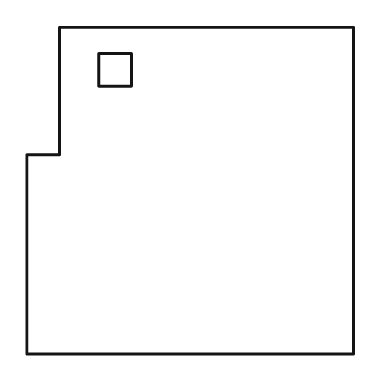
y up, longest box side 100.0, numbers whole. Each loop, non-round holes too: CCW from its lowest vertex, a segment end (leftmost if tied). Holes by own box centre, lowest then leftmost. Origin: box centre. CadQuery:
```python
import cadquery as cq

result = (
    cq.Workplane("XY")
    .moveTo(-50.0, -50.0)
    .lineTo(50.0, -50.0)
    .lineTo(50.0, 50.0)
    .lineTo(-40.0, 50.0)
    .lineTo(-40.0, 11.0)
    .lineTo(-50.0, 11.0)
    .close()
    .moveTo(-28.0, 32.0)
    .lineTo(-18.0, 32.0)
    .lineTo(-18.0, 42.0)
    .lineTo(-28.0, 42.0)
    .close()
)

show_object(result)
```